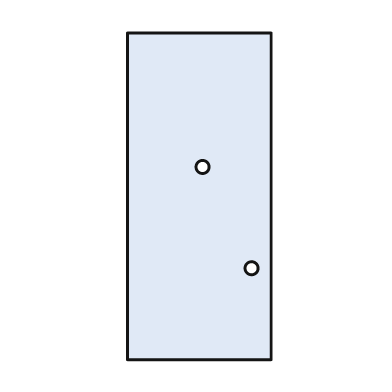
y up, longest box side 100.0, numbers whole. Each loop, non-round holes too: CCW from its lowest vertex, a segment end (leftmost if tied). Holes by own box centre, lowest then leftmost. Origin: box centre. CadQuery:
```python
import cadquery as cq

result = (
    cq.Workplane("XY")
    .moveTo(-22.0, -50.0)
    .lineTo(22.0, -50.0)
    .lineTo(22.0, 50.0)
    .lineTo(-22.0, 50.0)
    .close()
    .moveTo(16.0, -22.0)
    .circle(2.0)
    .moveTo(1.0, 9.0)
    .circle(2.0)
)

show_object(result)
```